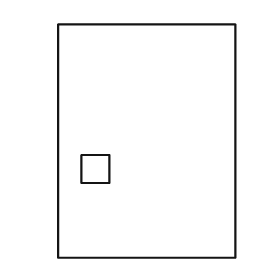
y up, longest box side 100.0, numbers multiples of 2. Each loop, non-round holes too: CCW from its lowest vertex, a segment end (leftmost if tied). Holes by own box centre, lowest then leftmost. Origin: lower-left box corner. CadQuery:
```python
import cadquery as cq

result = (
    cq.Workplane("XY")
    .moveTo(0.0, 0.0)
    .lineTo(76.0, 0.0)
    .lineTo(76.0, 100.0)
    .lineTo(0.0, 100.0)
    .close()
    .moveTo(10.0, 32.0)
    .lineTo(22.0, 32.0)
    .lineTo(22.0, 44.0)
    .lineTo(10.0, 44.0)
    .close()
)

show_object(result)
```